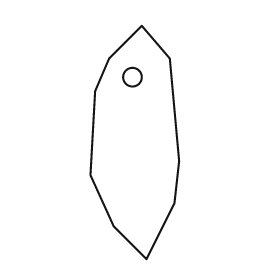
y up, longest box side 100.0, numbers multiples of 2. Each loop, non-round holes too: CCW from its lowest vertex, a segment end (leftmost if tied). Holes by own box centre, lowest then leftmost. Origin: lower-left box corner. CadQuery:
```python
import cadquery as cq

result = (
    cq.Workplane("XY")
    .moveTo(24.0, 0.0)
    .lineTo(36.0, 24.0)
    .lineTo(38.0, 42.0)
    .lineTo(34.0, 86.0)
    .lineTo(22.0, 100.0)
    .lineTo(8.0, 86.0)
    .lineTo(2.0, 72.0)
    .lineTo(0.0, 36.0)
    .lineTo(10.0, 14.0)
    .close()
    .moveTo(18.0, 78.0)
    .circle(4.0)
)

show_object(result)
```